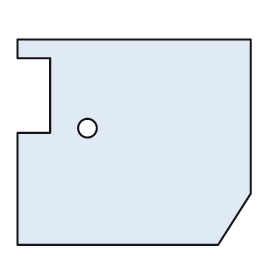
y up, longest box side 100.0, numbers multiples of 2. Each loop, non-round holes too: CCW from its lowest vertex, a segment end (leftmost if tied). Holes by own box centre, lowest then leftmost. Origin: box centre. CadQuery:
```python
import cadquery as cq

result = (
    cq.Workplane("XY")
    .moveTo(-50.0, -44.0)
    .lineTo(36.0, -44.0)
    .lineTo(50.0, -22.0)
    .lineTo(50.0, 44.0)
    .lineTo(-50.0, 44.0)
    .lineTo(-50.0, 36.0)
    .lineTo(-36.0, 36.0)
    .lineTo(-36.0, 4.0)
    .lineTo(-50.0, 4.0)
    .close()
    .moveTo(-20.0, 6.0)
    .circle(4.0)
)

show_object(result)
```